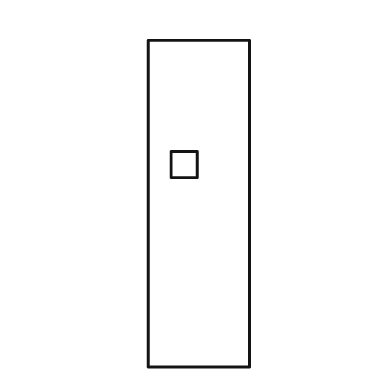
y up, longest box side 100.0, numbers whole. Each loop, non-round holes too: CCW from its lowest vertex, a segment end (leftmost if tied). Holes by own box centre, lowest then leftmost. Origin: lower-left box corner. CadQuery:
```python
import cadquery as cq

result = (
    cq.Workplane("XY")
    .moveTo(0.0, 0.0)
    .lineTo(31.0, 0.0)
    .lineTo(31.0, 100.0)
    .lineTo(0.0, 100.0)
    .close()
    .moveTo(7.0, 58.0)
    .lineTo(15.0, 58.0)
    .lineTo(15.0, 66.0)
    .lineTo(7.0, 66.0)
    .close()
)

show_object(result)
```